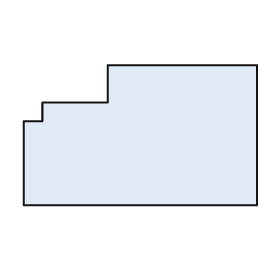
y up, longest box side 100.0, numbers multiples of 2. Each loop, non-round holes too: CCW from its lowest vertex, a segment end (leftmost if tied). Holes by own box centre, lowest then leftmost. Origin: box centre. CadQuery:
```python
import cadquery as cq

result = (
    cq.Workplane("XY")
    .moveTo(-50.0, -30.0)
    .lineTo(50.0, -30.0)
    .lineTo(50.0, 30.0)
    .lineTo(-14.0, 30.0)
    .lineTo(-14.0, 14.0)
    .lineTo(-42.0, 14.0)
    .lineTo(-42.0, 6.0)
    .lineTo(-50.0, 6.0)
    .close()
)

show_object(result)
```